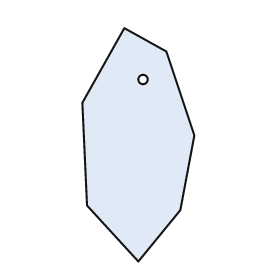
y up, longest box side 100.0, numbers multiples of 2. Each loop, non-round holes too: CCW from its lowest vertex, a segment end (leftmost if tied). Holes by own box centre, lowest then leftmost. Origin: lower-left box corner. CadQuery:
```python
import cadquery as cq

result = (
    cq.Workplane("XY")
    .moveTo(24.0, 0.0)
    .lineTo(42.0, 22.0)
    .lineTo(48.0, 54.0)
    .lineTo(36.0, 90.0)
    .lineTo(18.0, 100.0)
    .lineTo(0.0, 68.0)
    .lineTo(2.0, 24.0)
    .close()
    .moveTo(26.0, 78.0)
    .circle(2.0)
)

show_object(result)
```